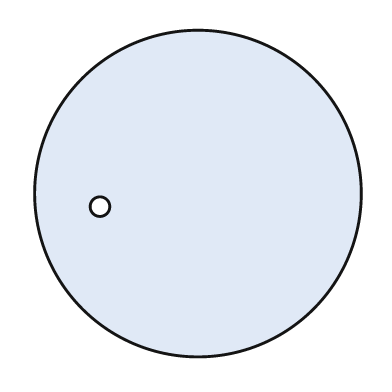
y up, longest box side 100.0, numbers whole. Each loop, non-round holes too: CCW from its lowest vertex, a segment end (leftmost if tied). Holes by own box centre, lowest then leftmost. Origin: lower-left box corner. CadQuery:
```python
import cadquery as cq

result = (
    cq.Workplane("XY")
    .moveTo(50.0, 50.0)
    .circle(50.0)
    .moveTo(20.0, 46.0)
    .circle(3.0)
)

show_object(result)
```